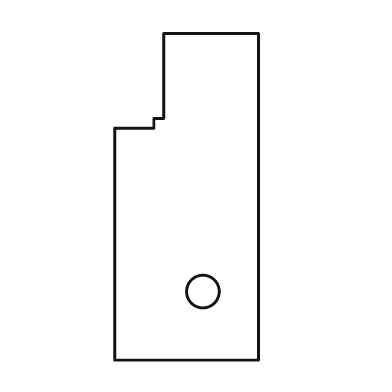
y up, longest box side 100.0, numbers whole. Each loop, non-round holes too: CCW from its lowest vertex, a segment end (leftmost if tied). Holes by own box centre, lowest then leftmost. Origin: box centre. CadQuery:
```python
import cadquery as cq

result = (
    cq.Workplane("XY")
    .moveTo(-22.0, -50.0)
    .lineTo(22.0, -50.0)
    .lineTo(22.0, 50.0)
    .lineTo(-7.0, 50.0)
    .lineTo(-7.0, 24.0)
    .lineTo(-10.0, 24.0)
    .lineTo(-10.0, 21.0)
    .lineTo(-22.0, 21.0)
    .close()
    .moveTo(5.0, -29.0)
    .circle(5.0)
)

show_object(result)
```